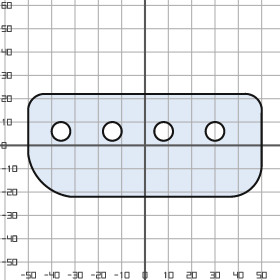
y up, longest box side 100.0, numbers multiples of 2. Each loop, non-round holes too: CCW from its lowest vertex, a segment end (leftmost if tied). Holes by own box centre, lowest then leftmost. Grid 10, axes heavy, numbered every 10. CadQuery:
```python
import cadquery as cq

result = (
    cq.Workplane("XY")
    .moveTo(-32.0, -22.0)
    .lineTo(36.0, -22.0)
    .threePointArc((46.0, -18.0), (50.0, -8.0))
    .lineTo(50.0, 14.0)
    .threePointArc((48.0, 20.0), (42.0, 22.0))
    .lineTo(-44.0, 22.0)
    .threePointArc((-48.0, 20.0), (-50.0, 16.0))
    .lineTo(-50.0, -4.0)
    .threePointArc((-44.0, -16.0), (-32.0, -22.0))
    .close()
    .moveTo(-36.0, 6.0)
    .circle(4.0)
    .moveTo(-14.0, 6.0)
    .circle(4.0)
    .moveTo(8.0, 6.0)
    .circle(4.0)
    .moveTo(30.0, 6.0)
    .circle(4.0)
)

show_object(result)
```